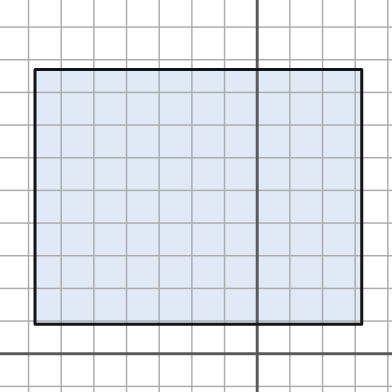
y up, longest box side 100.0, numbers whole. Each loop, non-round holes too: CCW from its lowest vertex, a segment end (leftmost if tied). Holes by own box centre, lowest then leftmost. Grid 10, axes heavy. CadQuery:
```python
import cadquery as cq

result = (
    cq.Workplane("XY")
    .moveTo(-68.0, 9.0)
    .lineTo(32.0, 9.0)
    .lineTo(32.0, 87.0)
    .lineTo(-68.0, 87.0)
    .close()
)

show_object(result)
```